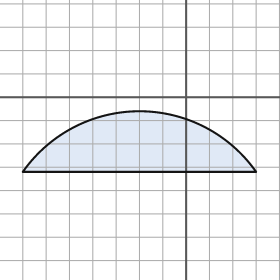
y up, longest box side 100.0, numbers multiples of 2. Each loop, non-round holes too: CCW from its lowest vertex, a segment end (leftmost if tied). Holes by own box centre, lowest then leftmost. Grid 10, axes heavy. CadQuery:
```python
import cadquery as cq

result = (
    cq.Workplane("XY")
    .moveTo(-70.0, -32.0)
    .lineTo(30.0, -32.0)
    .threePointArc((-20.0, -6.0), (-70.0, -32.0))
    .close()
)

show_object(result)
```